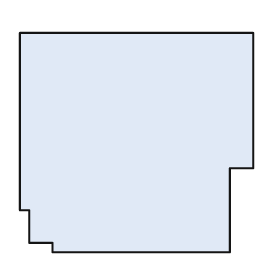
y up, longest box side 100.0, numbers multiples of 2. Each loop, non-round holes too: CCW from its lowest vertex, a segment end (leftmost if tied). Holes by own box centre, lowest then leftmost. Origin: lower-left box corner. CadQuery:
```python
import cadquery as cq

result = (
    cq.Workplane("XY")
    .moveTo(14.0, 0.0)
    .lineTo(90.0, 0.0)
    .lineTo(90.0, 36.0)
    .lineTo(100.0, 36.0)
    .lineTo(100.0, 94.0)
    .lineTo(0.0, 94.0)
    .lineTo(0.0, 18.0)
    .lineTo(4.0, 18.0)
    .lineTo(4.0, 4.0)
    .lineTo(14.0, 4.0)
    .close()
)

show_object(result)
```